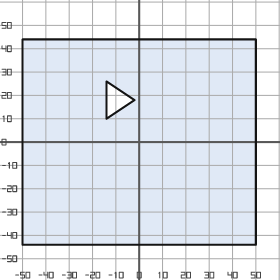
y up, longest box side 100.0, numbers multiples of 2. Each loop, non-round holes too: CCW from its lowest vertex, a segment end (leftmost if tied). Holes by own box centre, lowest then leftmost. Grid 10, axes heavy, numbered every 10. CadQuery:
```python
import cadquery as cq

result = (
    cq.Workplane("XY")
    .moveTo(-50.0, -44.0)
    .lineTo(50.0, -44.0)
    .lineTo(50.0, 44.0)
    .lineTo(-50.0, 44.0)
    .close()
    .moveTo(-14.0, 10.0)
    .lineTo(-2.0, 18.0)
    .lineTo(-14.0, 26.0)
    .close()
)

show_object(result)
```